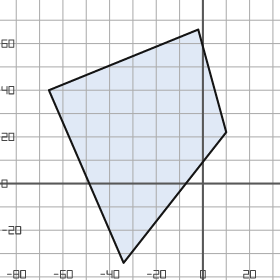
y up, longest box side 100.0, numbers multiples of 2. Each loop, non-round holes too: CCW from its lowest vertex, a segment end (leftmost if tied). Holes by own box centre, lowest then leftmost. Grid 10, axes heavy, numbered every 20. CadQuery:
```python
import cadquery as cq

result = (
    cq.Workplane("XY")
    .moveTo(-34.0, -34.0)
    .lineTo(10.0, 22.0)
    .lineTo(-2.0, 66.0)
    .lineTo(-66.0, 40.0)
    .close()
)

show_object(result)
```